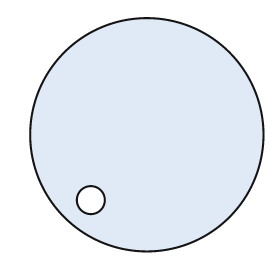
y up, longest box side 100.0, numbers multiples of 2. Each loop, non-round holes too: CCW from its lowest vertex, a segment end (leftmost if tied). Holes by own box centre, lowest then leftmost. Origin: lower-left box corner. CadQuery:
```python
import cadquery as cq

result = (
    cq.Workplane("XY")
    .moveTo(50.0, 50.0)
    .circle(50.0)
    .moveTo(26.0, 22.0)
    .circle(6.0)
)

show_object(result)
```